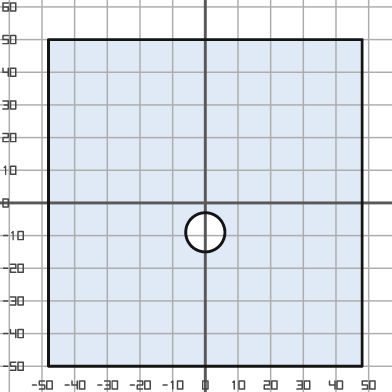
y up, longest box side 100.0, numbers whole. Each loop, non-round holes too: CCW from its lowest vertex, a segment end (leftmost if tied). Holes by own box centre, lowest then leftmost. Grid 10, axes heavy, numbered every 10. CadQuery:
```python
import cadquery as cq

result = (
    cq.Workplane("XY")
    .moveTo(-48.0, -50.0)
    .lineTo(48.0, -50.0)
    .lineTo(48.0, 50.0)
    .lineTo(-48.0, 50.0)
    .close()
    .moveTo(0.0, -9.0)
    .circle(6.0)
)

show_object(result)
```